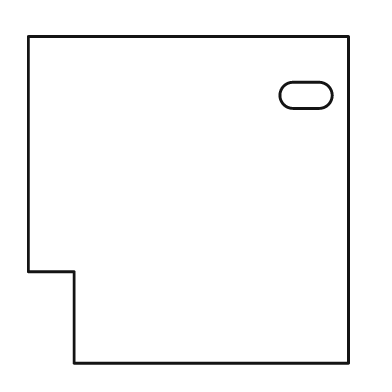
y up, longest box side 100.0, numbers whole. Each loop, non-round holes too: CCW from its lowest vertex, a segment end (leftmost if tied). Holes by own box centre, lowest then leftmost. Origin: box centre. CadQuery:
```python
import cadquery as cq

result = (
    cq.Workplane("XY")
    .moveTo(-35.0, -50.0)
    .lineTo(49.0, -50.0)
    .lineTo(49.0, 50.0)
    .lineTo(-49.0, 50.0)
    .lineTo(-49.0, -22.0)
    .lineTo(-35.0, -22.0)
    .close()
    .moveTo(32.0, 28.0)
    .lineTo(40.0, 28.0)
    .threePointArc((44.0, 32.0), (40.0, 36.0))
    .lineTo(32.0, 36.0)
    .threePointArc((28.0, 32.0), (32.0, 28.0))
    .close()
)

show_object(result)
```